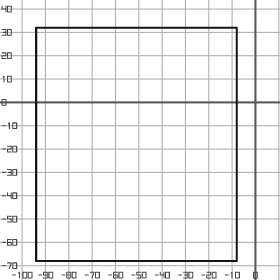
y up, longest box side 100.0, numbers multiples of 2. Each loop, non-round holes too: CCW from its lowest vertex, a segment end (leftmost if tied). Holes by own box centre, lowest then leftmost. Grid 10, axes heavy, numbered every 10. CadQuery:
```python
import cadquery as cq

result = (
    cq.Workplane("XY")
    .moveTo(-94.0, -68.0)
    .lineTo(-8.0, -68.0)
    .lineTo(-8.0, 32.0)
    .lineTo(-94.0, 32.0)
    .close()
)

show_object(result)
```